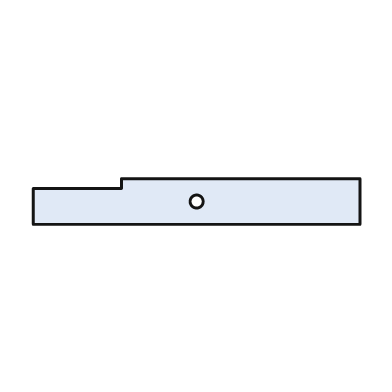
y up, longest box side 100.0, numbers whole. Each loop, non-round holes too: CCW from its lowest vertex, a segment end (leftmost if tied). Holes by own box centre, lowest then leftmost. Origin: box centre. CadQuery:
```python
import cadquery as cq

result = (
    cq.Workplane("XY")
    .moveTo(-50.0, -7.0)
    .lineTo(50.0, -7.0)
    .lineTo(50.0, 7.0)
    .lineTo(-23.0, 7.0)
    .lineTo(-23.0, 4.0)
    .lineTo(-50.0, 4.0)
    .close()
    .moveTo(0.0, 0.0)
    .circle(2.0)
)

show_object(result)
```